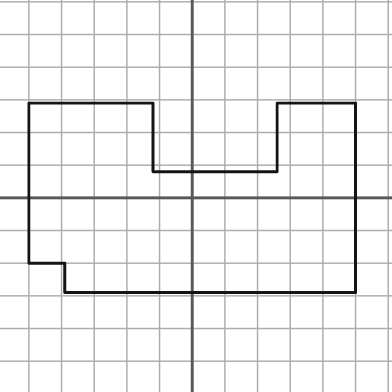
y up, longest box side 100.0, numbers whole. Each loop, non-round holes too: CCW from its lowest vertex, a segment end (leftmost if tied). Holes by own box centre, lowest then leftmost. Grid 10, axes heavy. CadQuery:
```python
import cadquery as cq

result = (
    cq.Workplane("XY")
    .moveTo(-39.0, -29.0)
    .lineTo(50.0, -29.0)
    .lineTo(50.0, 29.0)
    .lineTo(26.0, 29.0)
    .lineTo(26.0, 8.0)
    .lineTo(-12.0, 8.0)
    .lineTo(-12.0, 29.0)
    .lineTo(-50.0, 29.0)
    .lineTo(-50.0, -20.0)
    .lineTo(-39.0, -20.0)
    .close()
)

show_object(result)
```